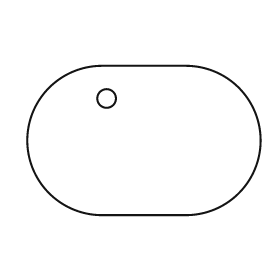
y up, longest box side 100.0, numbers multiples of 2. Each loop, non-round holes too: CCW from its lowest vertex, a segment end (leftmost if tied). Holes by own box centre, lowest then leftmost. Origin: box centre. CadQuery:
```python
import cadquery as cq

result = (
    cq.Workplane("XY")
    .moveTo(-18.0, -32.0)
    .lineTo(18.0, -32.0)
    .threePointArc((50.0, 0.0), (18.0, 32.0))
    .lineTo(-18.0, 32.0)
    .threePointArc((-50.0, 0.0), (-18.0, -32.0))
    .close()
    .moveTo(-16.0, 18.0)
    .circle(4.0)
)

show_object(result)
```